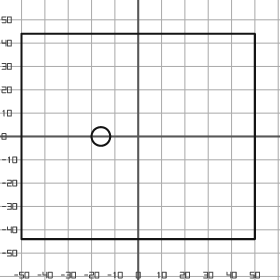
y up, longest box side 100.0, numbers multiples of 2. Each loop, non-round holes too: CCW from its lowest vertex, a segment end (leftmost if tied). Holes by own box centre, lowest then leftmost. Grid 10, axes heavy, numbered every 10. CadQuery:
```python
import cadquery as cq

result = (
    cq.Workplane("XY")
    .moveTo(-50.0, -44.0)
    .lineTo(50.0, -44.0)
    .lineTo(50.0, 44.0)
    .lineTo(-50.0, 44.0)
    .close()
    .moveTo(-16.0, 0.0)
    .circle(4.0)
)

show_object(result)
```